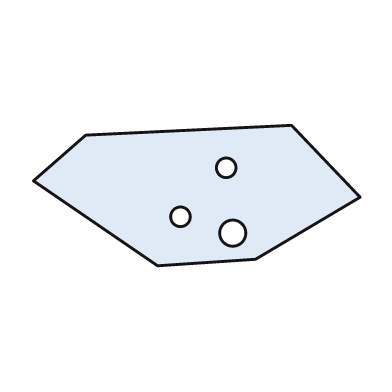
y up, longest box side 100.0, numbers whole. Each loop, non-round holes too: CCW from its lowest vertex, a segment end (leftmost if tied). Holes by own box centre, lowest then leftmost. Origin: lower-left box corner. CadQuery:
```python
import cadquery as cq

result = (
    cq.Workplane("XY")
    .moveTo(38.0, 0.0)
    .lineTo(68.0, 2.0)
    .lineTo(100.0, 21.0)
    .lineTo(79.0, 43.0)
    .lineTo(16.0, 40.0)
    .lineTo(0.0, 26.0)
    .close()
    .moveTo(61.0, 10.0)
    .circle(4.0)
    .moveTo(45.0, 15.0)
    .circle(3.0)
    .moveTo(59.0, 30.0)
    .circle(3.0)
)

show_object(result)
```